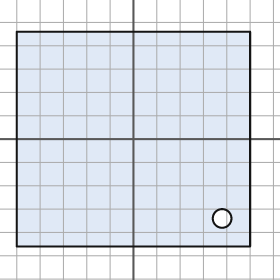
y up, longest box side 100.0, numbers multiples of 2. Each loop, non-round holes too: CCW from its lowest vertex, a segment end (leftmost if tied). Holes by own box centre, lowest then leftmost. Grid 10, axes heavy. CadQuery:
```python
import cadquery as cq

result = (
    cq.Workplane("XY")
    .moveTo(-50.0, -46.0)
    .lineTo(50.0, -46.0)
    .lineTo(50.0, 46.0)
    .lineTo(-50.0, 46.0)
    .close()
    .moveTo(38.0, -34.0)
    .circle(4.0)
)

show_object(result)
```